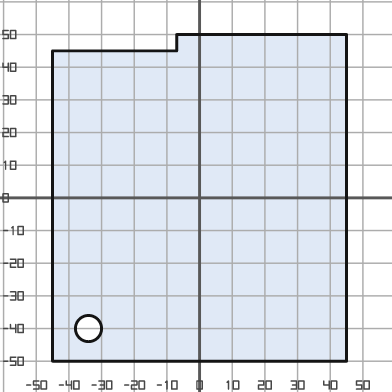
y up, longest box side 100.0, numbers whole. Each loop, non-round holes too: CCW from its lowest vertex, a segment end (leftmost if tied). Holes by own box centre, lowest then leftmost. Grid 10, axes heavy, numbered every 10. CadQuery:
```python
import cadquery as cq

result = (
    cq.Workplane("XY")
    .moveTo(-45.0, -50.0)
    .lineTo(45.0, -50.0)
    .lineTo(45.0, 50.0)
    .lineTo(-7.0, 50.0)
    .lineTo(-7.0, 45.0)
    .lineTo(-45.0, 45.0)
    .close()
    .moveTo(-34.0, -40.0)
    .circle(4.0)
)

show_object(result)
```